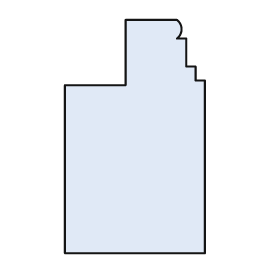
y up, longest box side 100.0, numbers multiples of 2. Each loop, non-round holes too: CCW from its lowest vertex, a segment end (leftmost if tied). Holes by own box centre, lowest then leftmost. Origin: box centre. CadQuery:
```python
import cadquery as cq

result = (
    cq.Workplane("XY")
    .moveTo(-30.0, -50.0)
    .lineTo(30.0, -50.0)
    .lineTo(30.0, 24.0)
    .lineTo(26.0, 24.0)
    .lineTo(26.0, 30.0)
    .lineTo(22.0, 30.0)
    .lineTo(22.0, 42.0)
    .lineTo(18.0, 42.0)
    .threePointArc((20.0, 46.0), (18.0, 50.0))
    .lineTo(-4.0, 50.0)
    .lineTo(-4.0, 22.0)
    .lineTo(-30.0, 22.0)
    .close()
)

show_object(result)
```